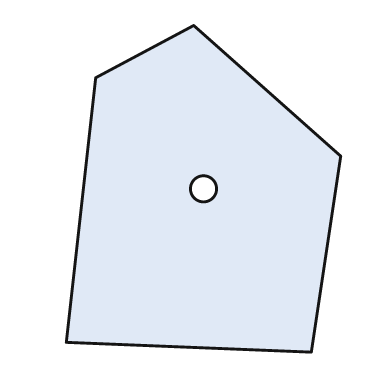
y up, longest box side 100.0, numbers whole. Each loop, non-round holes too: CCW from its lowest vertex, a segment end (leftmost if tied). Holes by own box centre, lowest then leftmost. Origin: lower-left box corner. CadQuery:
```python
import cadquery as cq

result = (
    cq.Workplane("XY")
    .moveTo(75.0, 0.0)
    .lineTo(84.0, 60.0)
    .lineTo(39.0, 100.0)
    .lineTo(9.0, 84.0)
    .lineTo(0.0, 3.0)
    .close()
    .moveTo(42.0, 50.0)
    .circle(4.0)
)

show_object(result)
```